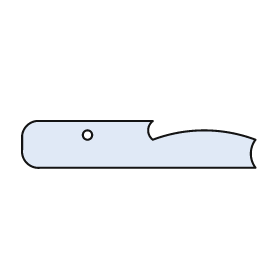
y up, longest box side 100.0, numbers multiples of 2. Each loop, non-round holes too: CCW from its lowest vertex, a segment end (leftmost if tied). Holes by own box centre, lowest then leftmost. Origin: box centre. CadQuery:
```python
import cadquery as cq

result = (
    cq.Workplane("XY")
    .moveTo(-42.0, -10.0)
    .lineTo(50.0, -10.0)
    .threePointArc((48.0, -4.0), (50.0, 2.0))
    .threePointArc((28.0, 6.0), (6.0, 2.0))
    .threePointArc((4.0, 6.0), (6.0, 10.0))
    .lineTo(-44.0, 10.0)
    .threePointArc((-48.0, 8.0), (-50.0, 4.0))
    .lineTo(-50.0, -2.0)
    .threePointArc((-48.0, -8.0), (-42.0, -10.0))
    .close()
    .moveTo(-22.0, 4.0)
    .circle(2.0)
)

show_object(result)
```